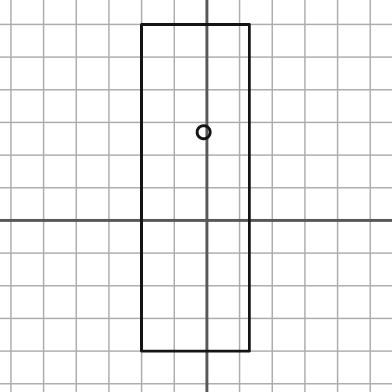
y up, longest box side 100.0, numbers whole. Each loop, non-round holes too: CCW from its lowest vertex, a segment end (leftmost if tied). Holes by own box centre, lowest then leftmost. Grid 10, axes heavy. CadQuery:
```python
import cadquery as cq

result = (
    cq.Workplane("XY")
    .moveTo(-20.0, -40.0)
    .lineTo(13.0, -40.0)
    .lineTo(13.0, 60.0)
    .lineTo(-20.0, 60.0)
    .close()
    .moveTo(-1.0, 27.0)
    .circle(2.0)
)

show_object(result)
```